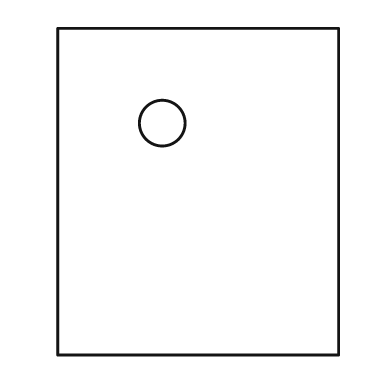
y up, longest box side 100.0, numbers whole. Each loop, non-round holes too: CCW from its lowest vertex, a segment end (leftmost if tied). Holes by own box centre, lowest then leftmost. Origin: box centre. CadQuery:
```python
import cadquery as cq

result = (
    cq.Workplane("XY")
    .moveTo(-43.0, -50.0)
    .lineTo(43.0, -50.0)
    .lineTo(43.0, 50.0)
    .lineTo(-43.0, 50.0)
    .close()
    .moveTo(-11.0, 21.0)
    .circle(7.0)
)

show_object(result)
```